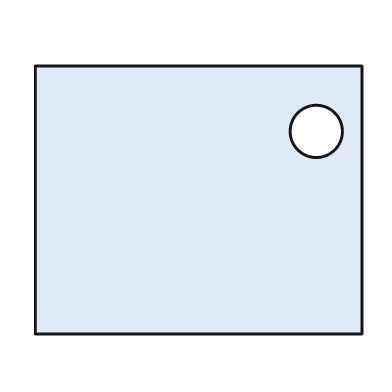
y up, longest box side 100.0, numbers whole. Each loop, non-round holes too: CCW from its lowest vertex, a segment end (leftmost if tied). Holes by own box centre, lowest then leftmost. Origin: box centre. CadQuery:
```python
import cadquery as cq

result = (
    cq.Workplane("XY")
    .moveTo(-50.0, -41.0)
    .lineTo(50.0, -41.0)
    .lineTo(50.0, 41.0)
    .lineTo(-50.0, 41.0)
    .close()
    .moveTo(36.0, 21.0)
    .circle(8.0)
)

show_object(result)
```